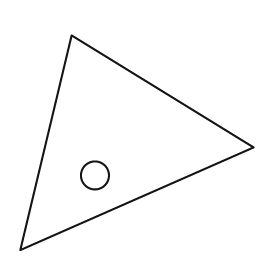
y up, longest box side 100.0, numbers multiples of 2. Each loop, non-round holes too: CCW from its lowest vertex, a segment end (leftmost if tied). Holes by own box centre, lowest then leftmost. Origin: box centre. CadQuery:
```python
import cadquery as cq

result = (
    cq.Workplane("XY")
    .moveTo(-50.0, -46.0)
    .lineTo(50.0, -2.0)
    .lineTo(-28.0, 46.0)
    .close()
    .moveTo(-18.0, -14.0)
    .circle(6.0)
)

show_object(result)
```